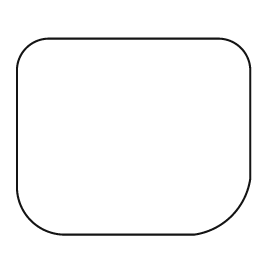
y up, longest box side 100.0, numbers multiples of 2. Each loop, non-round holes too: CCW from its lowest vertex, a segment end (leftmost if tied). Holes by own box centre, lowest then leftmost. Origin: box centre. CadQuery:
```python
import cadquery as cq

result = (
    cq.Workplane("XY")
    .moveTo(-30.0, -42.0)
    .lineTo(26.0, -42.0)
    .threePointArc((42.0, -34.0), (50.0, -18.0))
    .lineTo(50.0, 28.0)
    .threePointArc((46.0, 38.0), (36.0, 42.0))
    .lineTo(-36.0, 42.0)
    .threePointArc((-46.0, 38.0), (-50.0, 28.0))
    .lineTo(-50.0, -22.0)
    .threePointArc((-44.0, -36.0), (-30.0, -42.0))
    .close()
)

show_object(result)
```